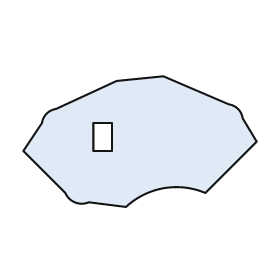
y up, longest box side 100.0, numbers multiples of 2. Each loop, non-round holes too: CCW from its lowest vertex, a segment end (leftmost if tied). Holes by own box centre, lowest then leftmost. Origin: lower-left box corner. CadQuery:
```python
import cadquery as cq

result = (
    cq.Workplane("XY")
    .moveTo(44.0, 0.0)
    .threePointArc((60.0, 8.0), (78.0, 6.0))
    .lineTo(100.0, 28.0)
    .lineTo(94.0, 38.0)
    .threePointArc((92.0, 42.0), (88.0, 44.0))
    .lineTo(60.0, 56.0)
    .lineTo(40.0, 54.0)
    .lineTo(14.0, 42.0)
    .threePointArc((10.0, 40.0), (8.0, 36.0))
    .lineTo(0.0, 24.0)
    .lineTo(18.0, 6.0)
    .threePointArc((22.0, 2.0), (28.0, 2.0))
    .close()
    .moveTo(30.0, 24.0)
    .lineTo(38.0, 24.0)
    .lineTo(38.0, 36.0)
    .lineTo(30.0, 36.0)
    .close()
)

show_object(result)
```